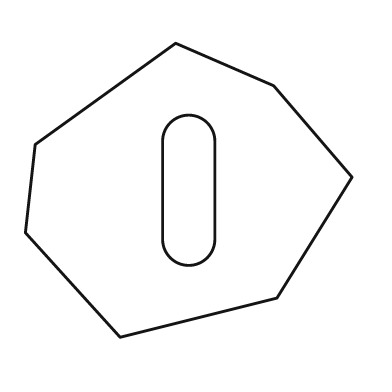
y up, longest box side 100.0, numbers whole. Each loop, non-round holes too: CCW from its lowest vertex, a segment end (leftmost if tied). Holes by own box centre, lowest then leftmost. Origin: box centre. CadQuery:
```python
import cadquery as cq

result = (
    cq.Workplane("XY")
    .moveTo(-21.0, -45.0)
    .lineTo(27.0, -33.0)
    .lineTo(50.0, 4.0)
    .lineTo(26.0, 32.0)
    .lineTo(-4.0, 45.0)
    .lineTo(-47.0, 14.0)
    .lineTo(-50.0, -13.0)
    .close()
    .moveTo(-8.0, -15.0)
    .threePointArc((0.0, -23.0), (8.0, -15.0))
    .lineTo(8.0, 15.0)
    .threePointArc((0.0, 23.0), (-8.0, 15.0))
    .close()
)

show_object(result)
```